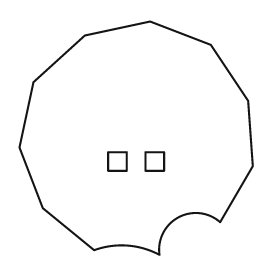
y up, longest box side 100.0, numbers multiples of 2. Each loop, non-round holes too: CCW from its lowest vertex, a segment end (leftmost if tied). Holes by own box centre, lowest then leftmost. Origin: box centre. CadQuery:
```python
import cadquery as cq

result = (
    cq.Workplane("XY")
    .moveTo(10.0, -50.0)
    .threePointArc((18.0, -34.0), (36.0, -36.0))
    .lineTo(50.0, -12.0)
    .lineTo(48.0, 16.0)
    .lineTo(32.0, 40.0)
    .lineTo(6.0, 50.0)
    .lineTo(-22.0, 44.0)
    .lineTo(-44.0, 24.0)
    .lineTo(-50.0, -4.0)
    .lineTo(-40.0, -30.0)
    .lineTo(-18.0, -48.0)
    .threePointArc((-4.0, -46.0), (10.0, -50.0))
    .close()
    .moveTo(-12.0, -14.0)
    .lineTo(-4.0, -14.0)
    .lineTo(-4.0, -6.0)
    .lineTo(-12.0, -6.0)
    .close()
    .moveTo(4.0, -14.0)
    .lineTo(12.0, -14.0)
    .lineTo(12.0, -6.0)
    .lineTo(4.0, -6.0)
    .close()
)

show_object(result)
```